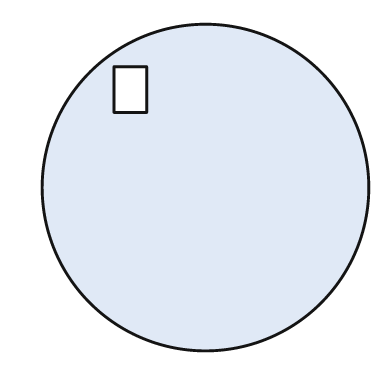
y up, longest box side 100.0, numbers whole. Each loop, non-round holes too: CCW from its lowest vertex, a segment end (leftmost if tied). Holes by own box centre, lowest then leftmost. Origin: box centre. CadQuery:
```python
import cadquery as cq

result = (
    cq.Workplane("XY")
    .moveTo(0.0, 0.0)
    .circle(50.0)
    .moveTo(-28.0, 23.0)
    .lineTo(-18.0, 23.0)
    .lineTo(-18.0, 37.0)
    .lineTo(-28.0, 37.0)
    .close()
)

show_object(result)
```